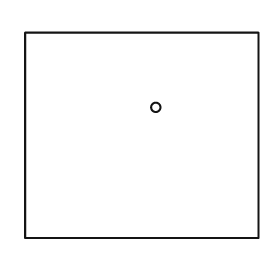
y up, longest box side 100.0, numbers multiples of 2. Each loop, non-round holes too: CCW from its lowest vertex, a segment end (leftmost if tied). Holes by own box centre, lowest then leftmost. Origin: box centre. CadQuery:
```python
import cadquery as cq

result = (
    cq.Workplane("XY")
    .moveTo(-50.0, -44.0)
    .lineTo(50.0, -44.0)
    .lineTo(50.0, 44.0)
    .lineTo(-50.0, 44.0)
    .close()
    .moveTo(6.0, 12.0)
    .circle(2.0)
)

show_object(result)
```